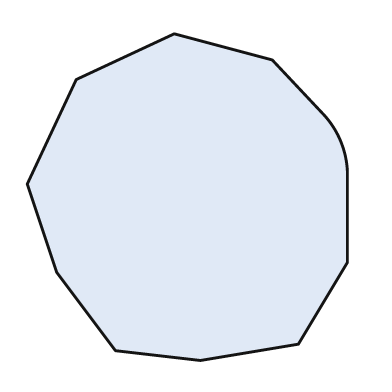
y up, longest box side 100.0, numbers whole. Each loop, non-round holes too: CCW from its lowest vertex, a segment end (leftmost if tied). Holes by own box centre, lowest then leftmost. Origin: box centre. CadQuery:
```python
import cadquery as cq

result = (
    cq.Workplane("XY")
    .moveTo(4.0, -50.0)
    .lineTo(34.0, -45.0)
    .lineTo(49.0, -20.0)
    .lineTo(49.0, 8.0)
    .threePointArc((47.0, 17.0), (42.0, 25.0))
    .lineTo(26.0, 42.0)
    .lineTo(-4.0, 50.0)
    .lineTo(-34.0, 36.0)
    .lineTo(-49.0, 4.0)
    .lineTo(-40.0, -23.0)
    .lineTo(-22.0, -47.0)
    .close()
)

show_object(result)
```